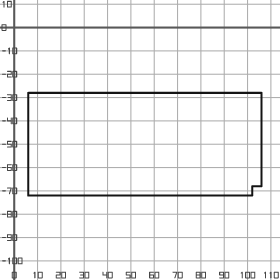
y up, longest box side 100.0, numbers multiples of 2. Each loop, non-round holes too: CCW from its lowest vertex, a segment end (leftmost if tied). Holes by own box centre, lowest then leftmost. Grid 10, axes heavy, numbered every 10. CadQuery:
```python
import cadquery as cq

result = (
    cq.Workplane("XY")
    .moveTo(6.0, -72.0)
    .lineTo(102.0, -72.0)
    .lineTo(102.0, -68.0)
    .lineTo(106.0, -68.0)
    .lineTo(106.0, -28.0)
    .lineTo(6.0, -28.0)
    .close()
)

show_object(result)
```